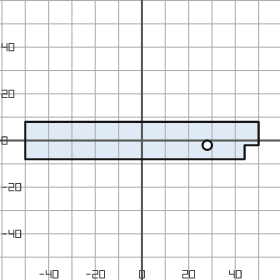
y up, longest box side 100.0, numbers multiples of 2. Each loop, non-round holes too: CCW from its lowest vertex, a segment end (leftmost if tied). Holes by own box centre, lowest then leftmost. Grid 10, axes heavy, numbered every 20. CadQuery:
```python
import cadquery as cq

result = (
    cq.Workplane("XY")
    .moveTo(-50.0, -8.0)
    .lineTo(44.0, -8.0)
    .lineTo(44.0, -2.0)
    .lineTo(50.0, -2.0)
    .lineTo(50.0, 8.0)
    .lineTo(-50.0, 8.0)
    .close()
    .moveTo(28.0, -2.0)
    .circle(2.0)
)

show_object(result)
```